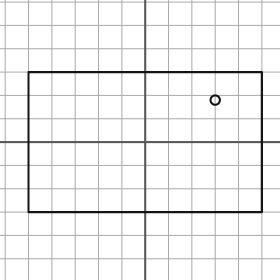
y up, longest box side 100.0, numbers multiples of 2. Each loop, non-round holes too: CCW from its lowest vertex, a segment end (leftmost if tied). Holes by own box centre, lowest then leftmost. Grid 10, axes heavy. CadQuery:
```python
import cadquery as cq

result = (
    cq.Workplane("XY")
    .moveTo(-50.0, -30.0)
    .lineTo(50.0, -30.0)
    .lineTo(50.0, 30.0)
    .lineTo(-50.0, 30.0)
    .close()
    .moveTo(30.0, 18.0)
    .circle(2.0)
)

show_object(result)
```